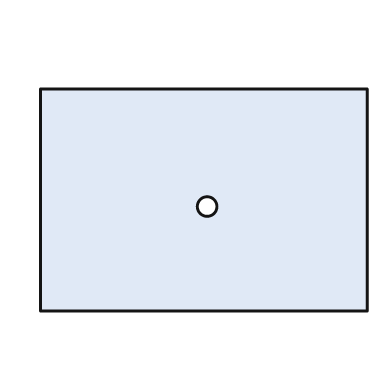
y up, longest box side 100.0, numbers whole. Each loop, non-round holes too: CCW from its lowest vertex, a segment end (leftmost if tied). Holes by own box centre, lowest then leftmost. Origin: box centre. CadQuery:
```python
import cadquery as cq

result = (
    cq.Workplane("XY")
    .moveTo(-50.0, -34.0)
    .lineTo(50.0, -34.0)
    .lineTo(50.0, 34.0)
    .lineTo(-50.0, 34.0)
    .close()
    .moveTo(1.0, -2.0)
    .circle(3.0)
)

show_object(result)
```